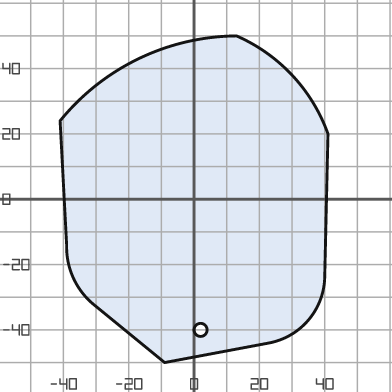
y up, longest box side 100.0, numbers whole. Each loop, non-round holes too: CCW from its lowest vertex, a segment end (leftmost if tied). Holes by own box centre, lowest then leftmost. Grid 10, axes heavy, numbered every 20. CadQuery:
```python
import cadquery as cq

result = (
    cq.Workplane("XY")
    .moveTo(-9.0, -50.0)
    .lineTo(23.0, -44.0)
    .threePointArc((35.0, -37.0), (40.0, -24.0))
    .lineTo(41.0, 20.0)
    .threePointArc((30.0, 38.0), (13.0, 50.0))
    .threePointArc((-17.0, 43.0), (-41.0, 24.0))
    .lineTo(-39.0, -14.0)
    .threePointArc((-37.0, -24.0), (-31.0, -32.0))
    .close()
    .moveTo(2.0, -40.0)
    .circle(2.0)
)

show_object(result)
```